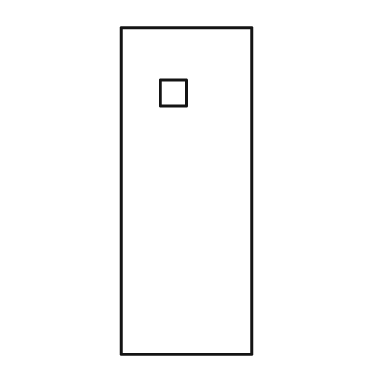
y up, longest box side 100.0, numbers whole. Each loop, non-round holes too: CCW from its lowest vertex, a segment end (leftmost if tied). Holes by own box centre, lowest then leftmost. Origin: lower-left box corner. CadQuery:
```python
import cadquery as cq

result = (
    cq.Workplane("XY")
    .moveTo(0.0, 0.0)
    .lineTo(40.0, 0.0)
    .lineTo(40.0, 100.0)
    .lineTo(0.0, 100.0)
    .close()
    .moveTo(12.0, 76.0)
    .lineTo(20.0, 76.0)
    .lineTo(20.0, 84.0)
    .lineTo(12.0, 84.0)
    .close()
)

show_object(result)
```